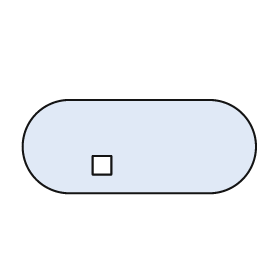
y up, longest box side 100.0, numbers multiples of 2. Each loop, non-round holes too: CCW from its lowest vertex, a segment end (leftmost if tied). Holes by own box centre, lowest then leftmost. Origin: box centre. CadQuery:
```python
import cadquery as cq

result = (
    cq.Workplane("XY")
    .moveTo(-30.0, -20.0)
    .lineTo(30.0, -20.0)
    .threePointArc((50.0, 0.0), (30.0, 20.0))
    .lineTo(-30.0, 20.0)
    .threePointArc((-50.0, 0.0), (-30.0, -20.0))
    .close()
    .moveTo(-20.0, -12.0)
    .lineTo(-12.0, -12.0)
    .lineTo(-12.0, -4.0)
    .lineTo(-20.0, -4.0)
    .close()
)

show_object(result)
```